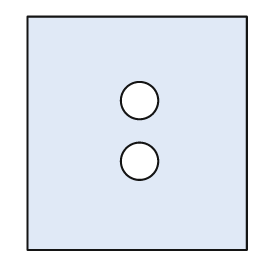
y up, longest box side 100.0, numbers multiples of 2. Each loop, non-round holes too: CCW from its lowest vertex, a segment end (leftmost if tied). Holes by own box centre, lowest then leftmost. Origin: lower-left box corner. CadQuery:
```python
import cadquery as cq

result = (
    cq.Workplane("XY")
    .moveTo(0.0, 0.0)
    .lineTo(94.0, 0.0)
    .lineTo(94.0, 100.0)
    .lineTo(0.0, 100.0)
    .close()
    .moveTo(48.0, 38.0)
    .circle(8.0)
    .moveTo(48.0, 64.0)
    .circle(8.0)
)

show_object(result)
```